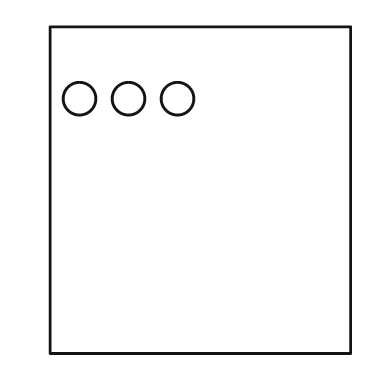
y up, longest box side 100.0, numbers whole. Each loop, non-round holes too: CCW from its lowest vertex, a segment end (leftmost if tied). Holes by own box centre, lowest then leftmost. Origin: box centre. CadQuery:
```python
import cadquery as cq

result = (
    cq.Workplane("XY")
    .moveTo(-46.0, -50.0)
    .lineTo(46.0, -50.0)
    .lineTo(46.0, 50.0)
    .lineTo(-46.0, 50.0)
    .close()
    .moveTo(-37.0, 28.0)
    .circle(5.0)
    .moveTo(-22.0, 28.0)
    .circle(5.0)
    .moveTo(-7.0, 28.0)
    .circle(5.0)
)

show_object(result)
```